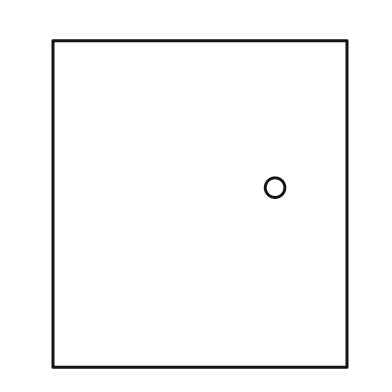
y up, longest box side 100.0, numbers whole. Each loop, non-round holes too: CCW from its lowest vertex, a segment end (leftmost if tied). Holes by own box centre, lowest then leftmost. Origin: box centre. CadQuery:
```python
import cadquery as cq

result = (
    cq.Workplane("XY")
    .moveTo(-45.0, -50.0)
    .lineTo(45.0, -50.0)
    .lineTo(45.0, 50.0)
    .lineTo(-45.0, 50.0)
    .close()
    .moveTo(23.0, 5.0)
    .circle(3.0)
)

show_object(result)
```